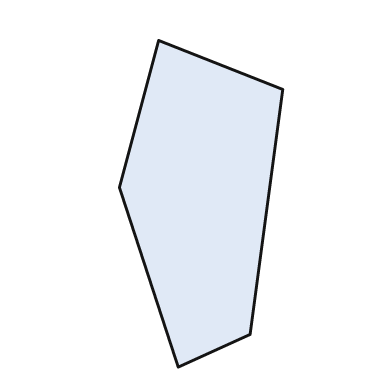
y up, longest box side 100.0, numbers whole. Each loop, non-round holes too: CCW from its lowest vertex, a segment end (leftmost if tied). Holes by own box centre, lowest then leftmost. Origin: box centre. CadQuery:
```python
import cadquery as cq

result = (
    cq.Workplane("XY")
    .moveTo(-7.0, -50.0)
    .lineTo(15.0, -40.0)
    .lineTo(25.0, 35.0)
    .lineTo(-13.0, 50.0)
    .lineTo(-25.0, 5.0)
    .close()
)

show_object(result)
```